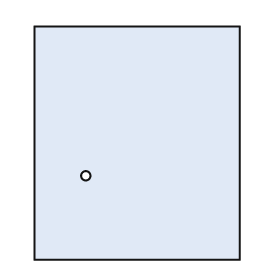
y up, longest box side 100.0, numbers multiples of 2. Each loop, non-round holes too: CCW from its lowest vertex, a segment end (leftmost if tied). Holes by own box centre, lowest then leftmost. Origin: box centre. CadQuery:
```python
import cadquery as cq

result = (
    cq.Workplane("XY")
    .moveTo(-44.0, -50.0)
    .lineTo(44.0, -50.0)
    .lineTo(44.0, 50.0)
    .lineTo(-44.0, 50.0)
    .close()
    .moveTo(-22.0, -14.0)
    .circle(2.0)
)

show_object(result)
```